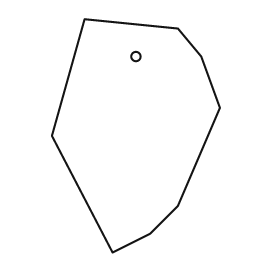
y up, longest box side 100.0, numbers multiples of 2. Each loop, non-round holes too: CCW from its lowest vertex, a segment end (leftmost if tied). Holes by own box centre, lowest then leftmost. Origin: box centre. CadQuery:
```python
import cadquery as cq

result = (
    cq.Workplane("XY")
    .moveTo(-10.0, -50.0)
    .lineTo(6.0, -42.0)
    .lineTo(18.0, -30.0)
    .lineTo(36.0, 12.0)
    .lineTo(28.0, 34.0)
    .lineTo(18.0, 46.0)
    .lineTo(-22.0, 50.0)
    .lineTo(-36.0, 0.0)
    .close()
    .moveTo(0.0, 34.0)
    .circle(2.0)
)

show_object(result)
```